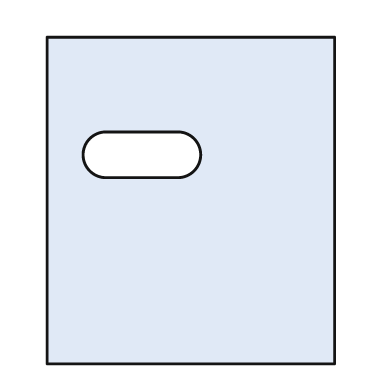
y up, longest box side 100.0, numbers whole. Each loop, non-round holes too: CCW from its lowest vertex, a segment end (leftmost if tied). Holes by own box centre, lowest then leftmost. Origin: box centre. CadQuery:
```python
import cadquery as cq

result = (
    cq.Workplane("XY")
    .moveTo(-44.0, -50.0)
    .lineTo(44.0, -50.0)
    .lineTo(44.0, 50.0)
    .lineTo(-44.0, 50.0)
    .close()
    .moveTo(-26.0, 7.0)
    .lineTo(-4.0, 7.0)
    .threePointArc((3.0, 14.0), (-4.0, 21.0))
    .lineTo(-26.0, 21.0)
    .threePointArc((-33.0, 14.0), (-26.0, 7.0))
    .close()
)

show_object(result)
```